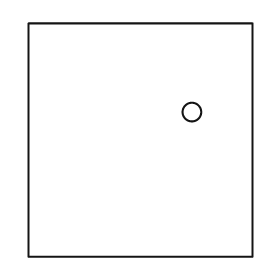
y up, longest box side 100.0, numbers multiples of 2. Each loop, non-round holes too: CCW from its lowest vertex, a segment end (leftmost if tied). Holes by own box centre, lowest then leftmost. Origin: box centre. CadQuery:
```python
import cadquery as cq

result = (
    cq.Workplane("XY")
    .moveTo(-48.0, -50.0)
    .lineTo(48.0, -50.0)
    .lineTo(48.0, 50.0)
    .lineTo(-48.0, 50.0)
    .close()
    .moveTo(22.0, 12.0)
    .circle(4.0)
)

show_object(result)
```